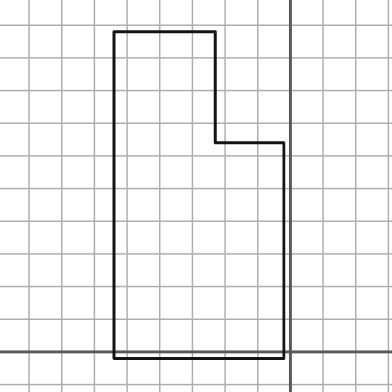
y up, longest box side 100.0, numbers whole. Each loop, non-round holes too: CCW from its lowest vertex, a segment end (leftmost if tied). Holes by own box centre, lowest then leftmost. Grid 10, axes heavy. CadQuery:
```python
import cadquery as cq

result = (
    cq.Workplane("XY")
    .moveTo(-54.0, -2.0)
    .lineTo(-2.0, -2.0)
    .lineTo(-2.0, 64.0)
    .lineTo(-23.0, 64.0)
    .lineTo(-23.0, 98.0)
    .lineTo(-54.0, 98.0)
    .close()
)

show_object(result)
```